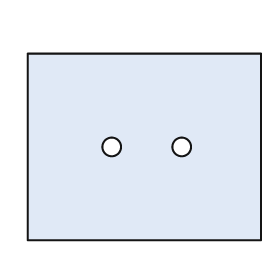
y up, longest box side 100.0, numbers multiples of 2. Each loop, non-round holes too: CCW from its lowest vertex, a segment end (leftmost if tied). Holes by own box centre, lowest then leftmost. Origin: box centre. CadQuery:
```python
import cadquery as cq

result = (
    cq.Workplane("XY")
    .moveTo(-50.0, -40.0)
    .lineTo(50.0, -40.0)
    .lineTo(50.0, 40.0)
    .lineTo(-50.0, 40.0)
    .close()
    .moveTo(-14.0, 0.0)
    .circle(4.0)
    .moveTo(16.0, 0.0)
    .circle(4.0)
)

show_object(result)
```